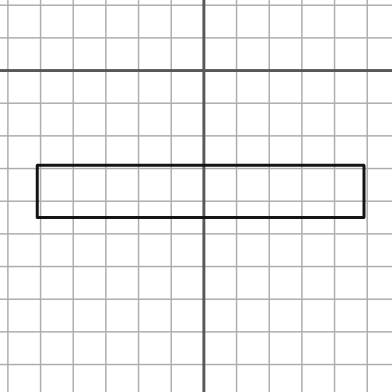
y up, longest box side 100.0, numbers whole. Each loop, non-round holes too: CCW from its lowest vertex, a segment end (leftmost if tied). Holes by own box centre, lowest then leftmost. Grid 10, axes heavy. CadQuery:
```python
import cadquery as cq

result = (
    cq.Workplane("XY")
    .moveTo(-51.0, -45.0)
    .lineTo(49.0, -45.0)
    .lineTo(49.0, -29.0)
    .lineTo(-51.0, -29.0)
    .close()
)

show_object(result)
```